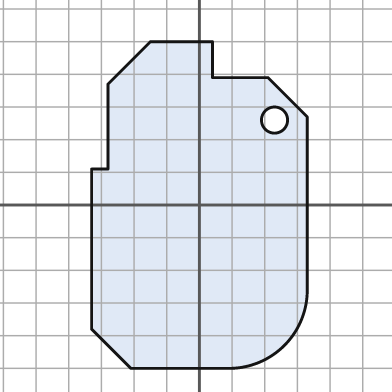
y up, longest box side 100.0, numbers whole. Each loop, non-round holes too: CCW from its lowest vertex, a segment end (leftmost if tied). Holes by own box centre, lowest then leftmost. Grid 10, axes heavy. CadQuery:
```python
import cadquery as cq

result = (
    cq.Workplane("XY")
    .moveTo(-21.0, -50.0)
    .lineTo(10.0, -50.0)
    .threePointArc((26.0, -43.0), (33.0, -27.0))
    .lineTo(33.0, 27.0)
    .lineTo(21.0, 39.0)
    .lineTo(4.0, 39.0)
    .lineTo(4.0, 50.0)
    .lineTo(-15.0, 50.0)
    .lineTo(-28.0, 37.0)
    .lineTo(-28.0, 11.0)
    .lineTo(-33.0, 11.0)
    .lineTo(-33.0, -38.0)
    .close()
    .moveTo(23.0, 26.0)
    .circle(4.0)
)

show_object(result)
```